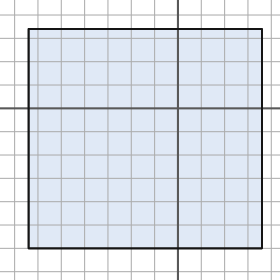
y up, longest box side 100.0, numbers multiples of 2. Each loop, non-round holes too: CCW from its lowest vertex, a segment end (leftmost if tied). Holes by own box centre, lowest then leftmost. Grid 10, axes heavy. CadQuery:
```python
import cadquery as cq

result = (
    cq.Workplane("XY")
    .moveTo(-64.0, -60.0)
    .lineTo(36.0, -60.0)
    .lineTo(36.0, 34.0)
    .lineTo(-64.0, 34.0)
    .close()
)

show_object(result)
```